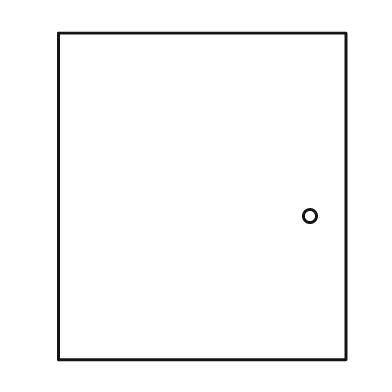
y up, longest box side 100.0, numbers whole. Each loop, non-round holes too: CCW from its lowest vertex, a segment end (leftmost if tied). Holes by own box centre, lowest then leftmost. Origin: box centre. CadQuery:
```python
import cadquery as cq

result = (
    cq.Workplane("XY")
    .moveTo(-44.0, -50.0)
    .lineTo(44.0, -50.0)
    .lineTo(44.0, 50.0)
    .lineTo(-44.0, 50.0)
    .close()
    .moveTo(33.0, -6.0)
    .circle(2.0)
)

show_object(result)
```